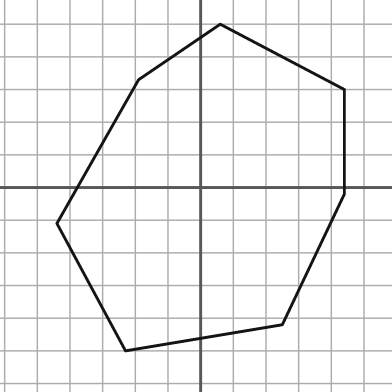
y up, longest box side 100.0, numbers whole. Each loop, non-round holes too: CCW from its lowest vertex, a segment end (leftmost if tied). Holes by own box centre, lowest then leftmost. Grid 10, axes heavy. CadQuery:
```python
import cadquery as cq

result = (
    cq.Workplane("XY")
    .moveTo(-23.0, -50.0)
    .lineTo(25.0, -42.0)
    .lineTo(44.0, -2.0)
    .lineTo(44.0, 30.0)
    .lineTo(6.0, 50.0)
    .lineTo(-19.0, 33.0)
    .lineTo(-44.0, -11.0)
    .close()
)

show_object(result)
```